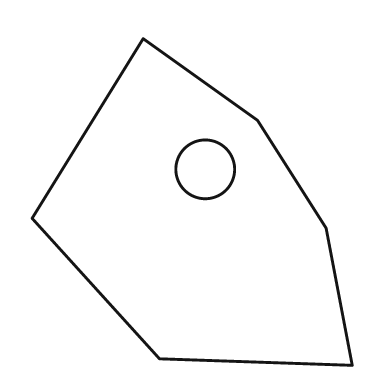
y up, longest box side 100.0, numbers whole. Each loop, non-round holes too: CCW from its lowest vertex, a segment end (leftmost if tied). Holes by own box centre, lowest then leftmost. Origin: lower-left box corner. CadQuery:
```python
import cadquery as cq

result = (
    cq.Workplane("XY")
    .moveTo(98.0, 0.0)
    .lineTo(90.0, 42.0)
    .lineTo(69.0, 75.0)
    .lineTo(34.0, 100.0)
    .lineTo(0.0, 45.0)
    .lineTo(39.0, 2.0)
    .close()
    .moveTo(53.0, 60.0)
    .circle(9.0)
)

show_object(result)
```